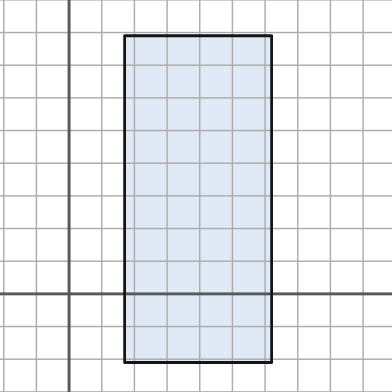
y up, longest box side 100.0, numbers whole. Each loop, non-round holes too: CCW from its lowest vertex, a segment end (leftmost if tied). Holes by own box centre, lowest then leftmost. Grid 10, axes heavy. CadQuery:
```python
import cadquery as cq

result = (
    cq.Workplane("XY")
    .moveTo(17.0, -21.0)
    .lineTo(62.0, -21.0)
    .lineTo(62.0, 79.0)
    .lineTo(17.0, 79.0)
    .close()
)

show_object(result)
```